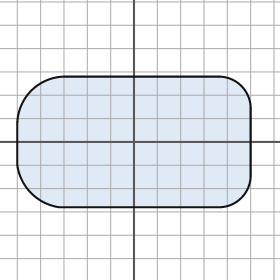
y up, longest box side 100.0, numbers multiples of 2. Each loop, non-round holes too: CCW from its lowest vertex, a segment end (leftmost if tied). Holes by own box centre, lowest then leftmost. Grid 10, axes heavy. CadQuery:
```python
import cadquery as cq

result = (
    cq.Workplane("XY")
    .moveTo(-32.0, -28.0)
    .lineTo(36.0, -28.0)
    .threePointArc((46.0, -24.0), (50.0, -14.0))
    .lineTo(50.0, 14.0)
    .threePointArc((46.0, 24.0), (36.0, 28.0))
    .lineTo(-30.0, 28.0)
    .threePointArc((-44.0, 22.0), (-50.0, 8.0))
    .lineTo(-50.0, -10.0)
    .threePointArc((-44.0, -22.0), (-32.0, -28.0))
    .close()
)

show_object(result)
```